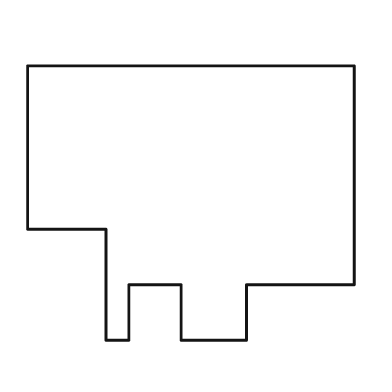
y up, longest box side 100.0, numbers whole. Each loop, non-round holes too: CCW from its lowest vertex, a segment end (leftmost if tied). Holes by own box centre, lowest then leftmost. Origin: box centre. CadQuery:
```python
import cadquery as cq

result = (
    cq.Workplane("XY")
    .moveTo(-26.0, -42.0)
    .lineTo(-19.0, -42.0)
    .lineTo(-19.0, -25.0)
    .lineTo(-3.0, -25.0)
    .lineTo(-3.0, -42.0)
    .lineTo(17.0, -42.0)
    .lineTo(17.0, -25.0)
    .lineTo(50.0, -25.0)
    .lineTo(50.0, 42.0)
    .lineTo(-50.0, 42.0)
    .lineTo(-50.0, -8.0)
    .lineTo(-26.0, -8.0)
    .close()
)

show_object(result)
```